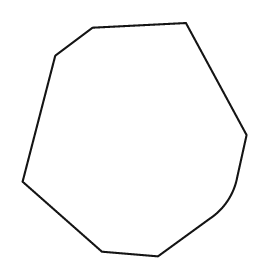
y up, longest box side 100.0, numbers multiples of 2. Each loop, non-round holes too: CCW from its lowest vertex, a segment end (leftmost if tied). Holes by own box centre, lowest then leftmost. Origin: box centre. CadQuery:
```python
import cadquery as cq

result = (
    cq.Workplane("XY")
    .moveTo(10.0, -50.0)
    .lineTo(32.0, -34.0)
    .threePointArc((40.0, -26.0), (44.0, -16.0))
    .lineTo(48.0, 2.0)
    .lineTo(22.0, 50.0)
    .lineTo(-18.0, 48.0)
    .lineTo(-34.0, 36.0)
    .lineTo(-48.0, -18.0)
    .lineTo(-14.0, -48.0)
    .close()
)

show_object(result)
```